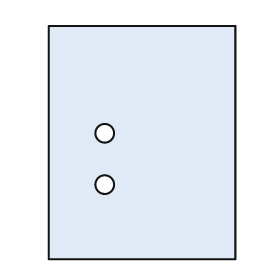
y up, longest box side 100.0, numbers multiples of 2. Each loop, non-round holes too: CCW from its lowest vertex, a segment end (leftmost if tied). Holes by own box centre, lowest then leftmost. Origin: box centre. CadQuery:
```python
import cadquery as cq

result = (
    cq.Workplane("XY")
    .moveTo(-40.0, -50.0)
    .lineTo(40.0, -50.0)
    .lineTo(40.0, 50.0)
    .lineTo(-40.0, 50.0)
    .close()
    .moveTo(-16.0, -18.0)
    .circle(4.0)
    .moveTo(-16.0, 4.0)
    .circle(4.0)
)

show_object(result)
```